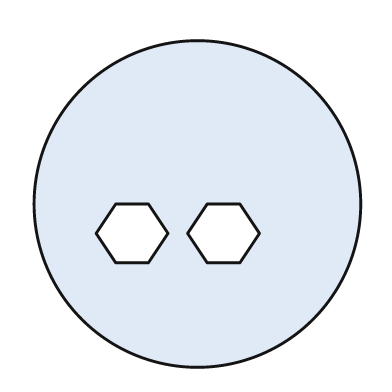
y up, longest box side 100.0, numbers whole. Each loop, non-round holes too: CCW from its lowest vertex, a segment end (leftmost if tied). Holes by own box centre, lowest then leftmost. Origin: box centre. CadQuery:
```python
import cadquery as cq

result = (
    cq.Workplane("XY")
    .moveTo(0.0, 0.0)
    .circle(50.0)
    .moveTo(-25.0, -18.0)
    .lineTo(-15.0, -18.0)
    .lineTo(-9.0, -9.0)
    .lineTo(-15.0, 0.0)
    .lineTo(-25.0, 0.0)
    .lineTo(-31.0, -9.0)
    .close()
    .moveTo(3.0, -18.0)
    .lineTo(13.0, -18.0)
    .lineTo(19.0, -9.0)
    .lineTo(13.0, 0.0)
    .lineTo(3.0, 0.0)
    .lineTo(-3.0, -9.0)
    .close()
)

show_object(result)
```